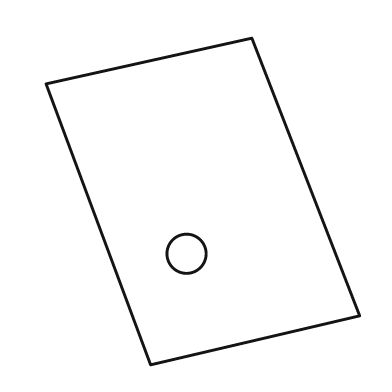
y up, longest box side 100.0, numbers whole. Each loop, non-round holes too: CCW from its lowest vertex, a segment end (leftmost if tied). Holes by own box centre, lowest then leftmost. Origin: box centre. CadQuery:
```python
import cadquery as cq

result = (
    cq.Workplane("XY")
    .moveTo(-16.0, -50.0)
    .lineTo(48.0, -35.0)
    .lineTo(15.0, 50.0)
    .lineTo(-48.0, 36.0)
    .close()
    .moveTo(-5.0, -16.0)
    .circle(6.0)
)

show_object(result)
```